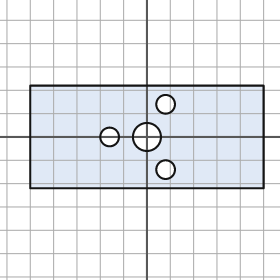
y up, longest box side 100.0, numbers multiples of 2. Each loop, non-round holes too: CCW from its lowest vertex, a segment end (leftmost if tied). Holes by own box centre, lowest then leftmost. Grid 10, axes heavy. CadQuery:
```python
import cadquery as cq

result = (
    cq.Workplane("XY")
    .moveTo(-50.0, -22.0)
    .lineTo(50.0, -22.0)
    .lineTo(50.0, 22.0)
    .lineTo(-50.0, 22.0)
    .close()
    .moveTo(8.0, -14.0)
    .circle(4.0)
    .moveTo(-16.0, 0.0)
    .circle(4.0)
    .moveTo(0.0, 0.0)
    .circle(6.0)
    .moveTo(8.0, 14.0)
    .circle(4.0)
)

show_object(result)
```